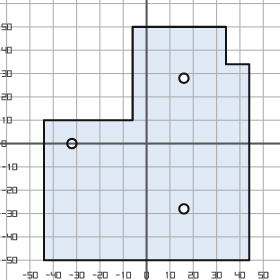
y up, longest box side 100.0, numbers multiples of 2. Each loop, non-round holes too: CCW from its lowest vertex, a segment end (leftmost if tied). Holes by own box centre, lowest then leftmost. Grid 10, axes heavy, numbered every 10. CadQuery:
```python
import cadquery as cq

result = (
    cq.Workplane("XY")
    .moveTo(-44.0, -50.0)
    .lineTo(44.0, -50.0)
    .lineTo(44.0, 34.0)
    .lineTo(34.0, 34.0)
    .lineTo(34.0, 50.0)
    .lineTo(-6.0, 50.0)
    .lineTo(-6.0, 10.0)
    .lineTo(-44.0, 10.0)
    .close()
    .moveTo(16.0, -28.0)
    .circle(2.0)
    .moveTo(-32.0, 0.0)
    .circle(2.0)
    .moveTo(16.0, 28.0)
    .circle(2.0)
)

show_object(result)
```